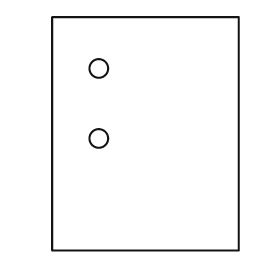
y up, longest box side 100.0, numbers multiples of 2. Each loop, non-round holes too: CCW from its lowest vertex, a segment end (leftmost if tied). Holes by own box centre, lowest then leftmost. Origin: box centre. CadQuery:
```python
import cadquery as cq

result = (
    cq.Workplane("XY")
    .moveTo(-40.0, -50.0)
    .lineTo(40.0, -50.0)
    .lineTo(40.0, 50.0)
    .lineTo(-40.0, 50.0)
    .close()
    .moveTo(-20.0, -2.0)
    .circle(4.0)
    .moveTo(-20.0, 28.0)
    .circle(4.0)
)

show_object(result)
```